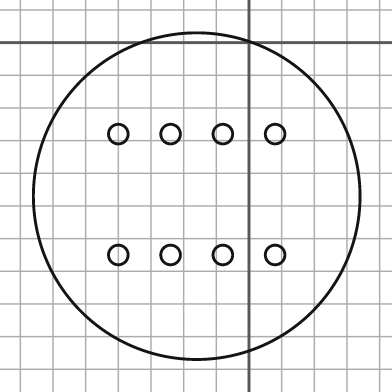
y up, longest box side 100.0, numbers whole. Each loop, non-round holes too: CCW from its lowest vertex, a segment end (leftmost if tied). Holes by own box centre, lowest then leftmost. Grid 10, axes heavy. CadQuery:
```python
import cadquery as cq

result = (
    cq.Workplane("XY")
    .moveTo(-16.0, -47.0)
    .circle(50.0)
    .moveTo(-40.0, -65.0)
    .circle(3.0)
    .moveTo(-24.0, -65.0)
    .circle(3.0)
    .moveTo(-8.0, -65.0)
    .circle(3.0)
    .moveTo(8.0, -65.0)
    .circle(3.0)
    .moveTo(-40.0, -28.0)
    .circle(3.0)
    .moveTo(-24.0, -28.0)
    .circle(3.0)
    .moveTo(-8.0, -28.0)
    .circle(3.0)
    .moveTo(8.0, -28.0)
    .circle(3.0)
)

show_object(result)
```